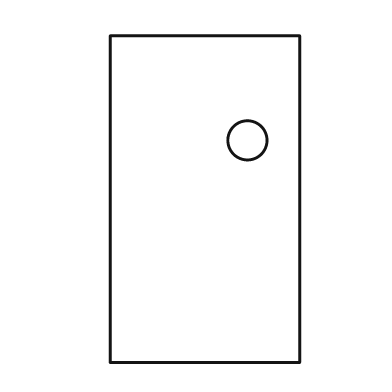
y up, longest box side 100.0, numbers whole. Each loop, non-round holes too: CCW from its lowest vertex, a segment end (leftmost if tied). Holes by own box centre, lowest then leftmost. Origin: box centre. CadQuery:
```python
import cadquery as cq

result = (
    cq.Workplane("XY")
    .moveTo(-29.0, -50.0)
    .lineTo(29.0, -50.0)
    .lineTo(29.0, 50.0)
    .lineTo(-29.0, 50.0)
    .close()
    .moveTo(13.0, 18.0)
    .circle(6.0)
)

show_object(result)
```